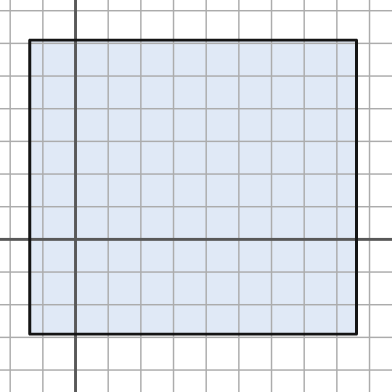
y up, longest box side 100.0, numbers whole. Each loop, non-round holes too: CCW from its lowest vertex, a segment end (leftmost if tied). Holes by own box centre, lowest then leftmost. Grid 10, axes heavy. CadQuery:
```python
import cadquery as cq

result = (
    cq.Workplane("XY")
    .moveTo(-14.0, -29.0)
    .lineTo(86.0, -29.0)
    .lineTo(86.0, 61.0)
    .lineTo(-14.0, 61.0)
    .close()
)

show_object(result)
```